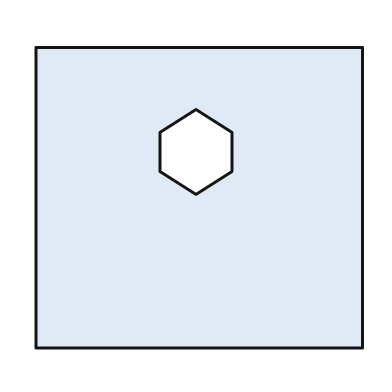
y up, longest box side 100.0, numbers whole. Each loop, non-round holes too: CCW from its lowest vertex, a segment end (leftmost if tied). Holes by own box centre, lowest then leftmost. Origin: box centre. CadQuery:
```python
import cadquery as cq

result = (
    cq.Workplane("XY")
    .moveTo(-50.0, -46.0)
    .lineTo(50.0, -46.0)
    .lineTo(50.0, 46.0)
    .lineTo(-50.0, 46.0)
    .close()
    .moveTo(-1.0, 1.0)
    .lineTo(10.0, 8.0)
    .lineTo(10.0, 20.0)
    .lineTo(-1.0, 27.0)
    .lineTo(-12.0, 20.0)
    .lineTo(-12.0, 8.0)
    .close()
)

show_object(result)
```